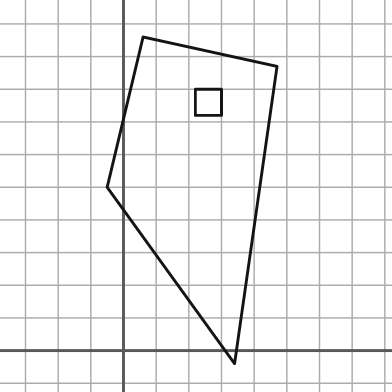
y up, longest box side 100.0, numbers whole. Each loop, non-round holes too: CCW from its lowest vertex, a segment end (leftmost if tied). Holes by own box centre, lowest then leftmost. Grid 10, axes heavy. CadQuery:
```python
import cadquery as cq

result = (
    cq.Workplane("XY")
    .moveTo(34.0, -4.0)
    .lineTo(47.0, 87.0)
    .lineTo(6.0, 96.0)
    .lineTo(-5.0, 50.0)
    .close()
    .moveTo(22.0, 72.0)
    .lineTo(30.0, 72.0)
    .lineTo(30.0, 80.0)
    .lineTo(22.0, 80.0)
    .close()
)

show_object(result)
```